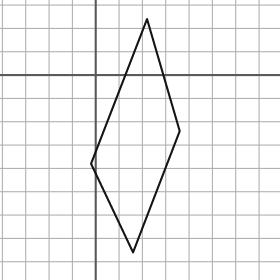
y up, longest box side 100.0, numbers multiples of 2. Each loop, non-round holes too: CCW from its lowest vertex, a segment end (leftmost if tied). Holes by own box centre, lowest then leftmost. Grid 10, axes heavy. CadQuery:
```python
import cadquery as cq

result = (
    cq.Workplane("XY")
    .moveTo(16.0, -76.0)
    .lineTo(36.0, -24.0)
    .lineTo(22.0, 24.0)
    .lineTo(-2.0, -38.0)
    .close()
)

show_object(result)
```